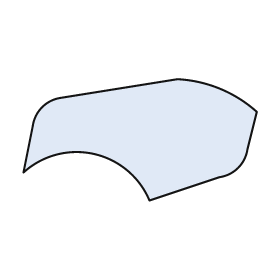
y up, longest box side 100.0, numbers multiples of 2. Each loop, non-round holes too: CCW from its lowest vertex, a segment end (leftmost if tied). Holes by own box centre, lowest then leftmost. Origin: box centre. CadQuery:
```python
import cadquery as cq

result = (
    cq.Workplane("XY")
    .moveTo(4.0, -26.0)
    .lineTo(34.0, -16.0)
    .threePointArc((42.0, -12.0), (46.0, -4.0))
    .lineTo(50.0, 12.0)
    .threePointArc((34.0, 22.0), (16.0, 26.0))
    .lineTo(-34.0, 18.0)
    .threePointArc((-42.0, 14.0), (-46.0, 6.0))
    .lineTo(-50.0, -14.0)
    .threePointArc((-20.0, -6.0), (4.0, -26.0))
    .close()
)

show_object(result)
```